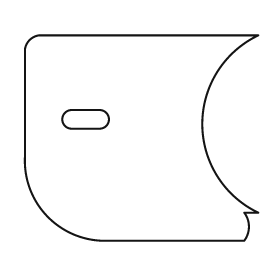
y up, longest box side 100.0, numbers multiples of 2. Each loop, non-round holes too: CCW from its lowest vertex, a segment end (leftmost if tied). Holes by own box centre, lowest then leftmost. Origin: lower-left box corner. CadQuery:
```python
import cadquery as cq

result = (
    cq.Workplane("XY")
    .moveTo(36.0, 0.0)
    .lineTo(94.0, 0.0)
    .threePointArc((96.0, 6.0), (94.0, 12.0))
    .lineTo(100.0, 12.0)
    .threePointArc((76.0, 50.0), (100.0, 88.0))
    .lineTo(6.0, 88.0)
    .threePointArc((2.0, 86.0), (0.0, 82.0))
    .lineTo(0.0, 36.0)
    .threePointArc((10.0, 10.0), (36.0, 0.0))
    .close()
    .moveTo(20.0, 48.0)
    .lineTo(32.0, 48.0)
    .threePointArc((36.0, 52.0), (32.0, 56.0))
    .lineTo(20.0, 56.0)
    .threePointArc((16.0, 52.0), (20.0, 48.0))
    .close()
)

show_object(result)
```